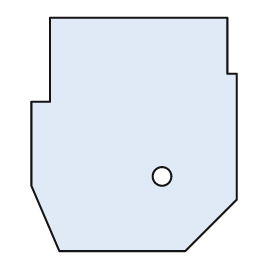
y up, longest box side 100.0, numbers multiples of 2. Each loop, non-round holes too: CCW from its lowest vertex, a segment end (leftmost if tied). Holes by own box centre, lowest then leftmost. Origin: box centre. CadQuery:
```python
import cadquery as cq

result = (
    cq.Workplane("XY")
    .moveTo(-32.0, -50.0)
    .lineTo(22.0, -50.0)
    .lineTo(44.0, -28.0)
    .lineTo(44.0, 26.0)
    .lineTo(40.0, 26.0)
    .lineTo(40.0, 50.0)
    .lineTo(-36.0, 50.0)
    .lineTo(-36.0, 14.0)
    .lineTo(-44.0, 14.0)
    .lineTo(-44.0, -22.0)
    .close()
    .moveTo(12.0, -18.0)
    .circle(4.0)
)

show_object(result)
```